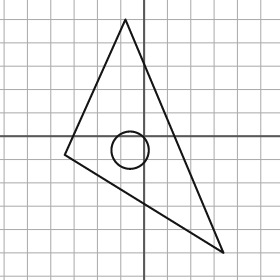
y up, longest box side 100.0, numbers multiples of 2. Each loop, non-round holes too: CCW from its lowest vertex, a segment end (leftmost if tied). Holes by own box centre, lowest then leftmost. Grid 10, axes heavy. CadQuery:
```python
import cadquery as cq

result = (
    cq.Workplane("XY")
    .moveTo(34.0, -50.0)
    .lineTo(-8.0, 50.0)
    .lineTo(-34.0, -8.0)
    .close()
    .moveTo(-6.0, -6.0)
    .circle(8.0)
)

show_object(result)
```